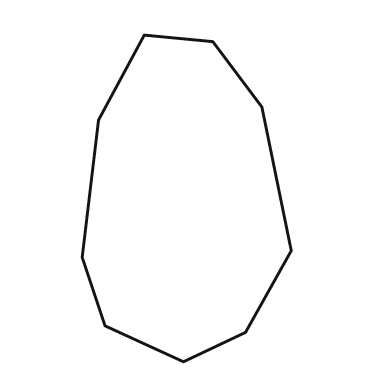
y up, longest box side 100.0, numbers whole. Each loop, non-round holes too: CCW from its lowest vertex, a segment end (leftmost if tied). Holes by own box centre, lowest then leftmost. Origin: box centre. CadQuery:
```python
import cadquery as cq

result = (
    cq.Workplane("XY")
    .moveTo(-1.0, -50.0)
    .lineTo(18.0, -41.0)
    .lineTo(32.0, -16.0)
    .lineTo(23.0, 28.0)
    .lineTo(8.0, 48.0)
    .lineTo(-13.0, 50.0)
    .lineTo(-27.0, 24.0)
    .lineTo(-32.0, -18.0)
    .lineTo(-25.0, -39.0)
    .close()
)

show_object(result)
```